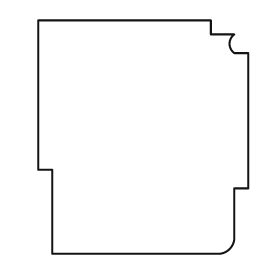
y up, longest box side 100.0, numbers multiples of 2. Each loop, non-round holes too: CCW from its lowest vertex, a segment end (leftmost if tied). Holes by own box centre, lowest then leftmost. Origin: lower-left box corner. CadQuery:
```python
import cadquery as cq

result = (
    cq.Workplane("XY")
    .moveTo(6.0, 0.0)
    .lineTo(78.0, 0.0)
    .threePointArc((82.0, 2.0), (84.0, 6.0))
    .lineTo(84.0, 28.0)
    .lineTo(90.0, 28.0)
    .lineTo(90.0, 86.0)
    .lineTo(84.0, 86.0)
    .threePointArc((82.0, 90.0), (84.0, 94.0))
    .lineTo(74.0, 94.0)
    .lineTo(74.0, 100.0)
    .lineTo(0.0, 100.0)
    .lineTo(0.0, 36.0)
    .lineTo(6.0, 36.0)
    .close()
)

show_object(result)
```